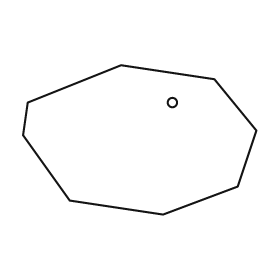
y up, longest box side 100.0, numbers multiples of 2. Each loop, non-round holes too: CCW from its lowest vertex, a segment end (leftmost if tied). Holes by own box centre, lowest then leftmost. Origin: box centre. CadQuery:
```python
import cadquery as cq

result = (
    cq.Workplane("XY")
    .moveTo(10.0, -32.0)
    .lineTo(42.0, -20.0)
    .lineTo(50.0, 4.0)
    .lineTo(32.0, 26.0)
    .lineTo(-8.0, 32.0)
    .lineTo(-48.0, 16.0)
    .lineTo(-50.0, 2.0)
    .lineTo(-30.0, -26.0)
    .close()
    .moveTo(14.0, 16.0)
    .circle(2.0)
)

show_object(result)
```